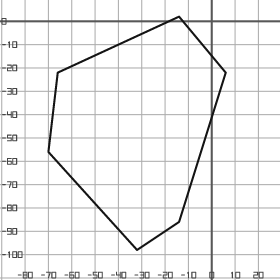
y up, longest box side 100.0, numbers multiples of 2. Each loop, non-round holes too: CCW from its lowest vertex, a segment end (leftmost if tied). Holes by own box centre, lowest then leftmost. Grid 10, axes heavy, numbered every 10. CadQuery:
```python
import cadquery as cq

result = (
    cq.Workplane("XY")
    .moveTo(-32.0, -98.0)
    .lineTo(-14.0, -86.0)
    .lineTo(6.0, -22.0)
    .lineTo(-14.0, 2.0)
    .lineTo(-66.0, -22.0)
    .lineTo(-70.0, -56.0)
    .close()
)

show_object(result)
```